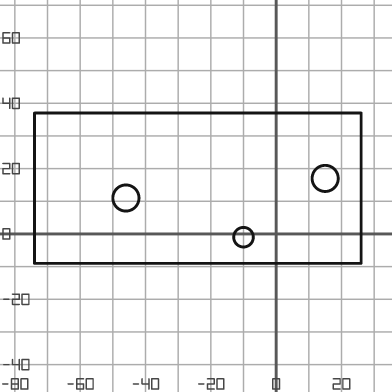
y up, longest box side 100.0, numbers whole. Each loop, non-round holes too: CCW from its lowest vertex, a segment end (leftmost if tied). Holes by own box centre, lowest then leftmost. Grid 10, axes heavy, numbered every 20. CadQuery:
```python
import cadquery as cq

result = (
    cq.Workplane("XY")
    .moveTo(-74.0, -9.0)
    .lineTo(26.0, -9.0)
    .lineTo(26.0, 37.0)
    .lineTo(-74.0, 37.0)
    .close()
    .moveTo(-10.0, -1.0)
    .circle(3.0)
    .moveTo(-46.0, 11.0)
    .circle(4.0)
    .moveTo(15.0, 17.0)
    .circle(4.0)
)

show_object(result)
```